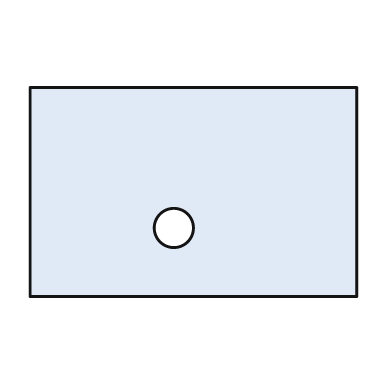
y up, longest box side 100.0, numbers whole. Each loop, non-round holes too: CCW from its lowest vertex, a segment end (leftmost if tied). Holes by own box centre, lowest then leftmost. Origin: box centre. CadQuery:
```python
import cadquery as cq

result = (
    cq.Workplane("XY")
    .moveTo(-50.0, -32.0)
    .lineTo(50.0, -32.0)
    .lineTo(50.0, 32.0)
    .lineTo(-50.0, 32.0)
    .close()
    .moveTo(-6.0, -11.0)
    .circle(6.0)
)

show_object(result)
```